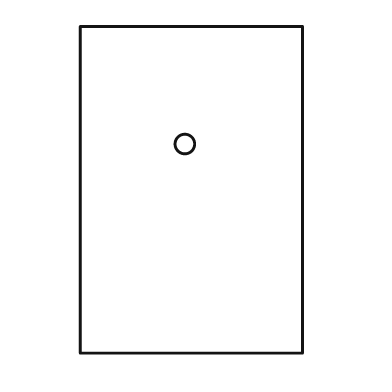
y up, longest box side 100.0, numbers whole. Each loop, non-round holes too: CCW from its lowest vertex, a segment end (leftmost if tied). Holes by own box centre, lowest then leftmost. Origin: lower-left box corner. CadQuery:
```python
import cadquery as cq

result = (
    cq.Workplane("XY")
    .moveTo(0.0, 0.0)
    .lineTo(68.0, 0.0)
    .lineTo(68.0, 100.0)
    .lineTo(0.0, 100.0)
    .close()
    .moveTo(32.0, 64.0)
    .circle(3.0)
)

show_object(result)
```